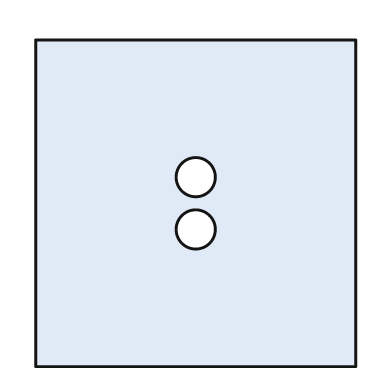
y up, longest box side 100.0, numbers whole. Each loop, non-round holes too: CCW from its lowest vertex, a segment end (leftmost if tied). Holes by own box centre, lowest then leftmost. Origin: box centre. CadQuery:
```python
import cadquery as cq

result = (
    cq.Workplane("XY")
    .moveTo(-49.0, -50.0)
    .lineTo(49.0, -50.0)
    .lineTo(49.0, 50.0)
    .lineTo(-49.0, 50.0)
    .close()
    .moveTo(0.0, -8.0)
    .circle(6.0)
    .moveTo(0.0, 8.0)
    .circle(6.0)
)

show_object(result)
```